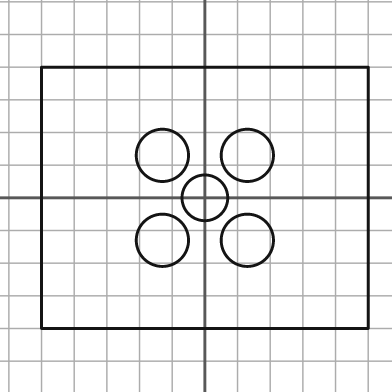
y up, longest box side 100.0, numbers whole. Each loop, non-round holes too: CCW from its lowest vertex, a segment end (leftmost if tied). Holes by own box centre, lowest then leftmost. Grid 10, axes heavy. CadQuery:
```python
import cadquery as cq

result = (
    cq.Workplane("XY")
    .moveTo(-50.0, -40.0)
    .lineTo(50.0, -40.0)
    .lineTo(50.0, 40.0)
    .lineTo(-50.0, 40.0)
    .close()
    .moveTo(-13.0, -13.0)
    .circle(8.0)
    .moveTo(13.0, -13.0)
    .circle(8.0)
    .moveTo(0.0, 0.0)
    .circle(7.0)
    .moveTo(-13.0, 13.0)
    .circle(8.0)
    .moveTo(13.0, 13.0)
    .circle(8.0)
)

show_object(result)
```